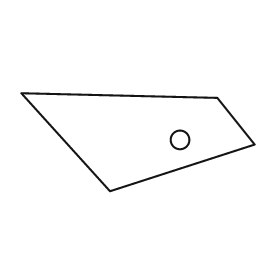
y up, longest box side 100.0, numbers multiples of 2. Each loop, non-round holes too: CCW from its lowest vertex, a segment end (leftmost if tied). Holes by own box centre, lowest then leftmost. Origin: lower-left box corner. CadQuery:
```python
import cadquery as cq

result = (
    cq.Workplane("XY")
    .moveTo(38.0, 0.0)
    .lineTo(100.0, 20.0)
    .lineTo(84.0, 40.0)
    .lineTo(0.0, 42.0)
    .close()
    .moveTo(68.0, 22.0)
    .circle(4.0)
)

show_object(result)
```